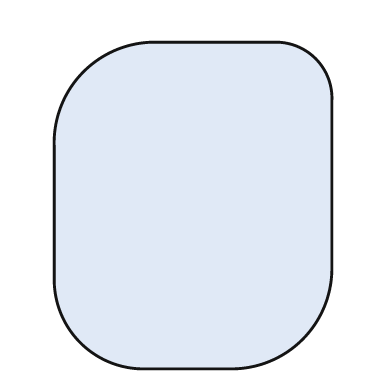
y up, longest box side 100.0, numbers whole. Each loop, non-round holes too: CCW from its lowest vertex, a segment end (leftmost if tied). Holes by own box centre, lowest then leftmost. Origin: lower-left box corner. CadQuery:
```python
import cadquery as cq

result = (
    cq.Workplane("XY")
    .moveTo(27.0, 0.0)
    .lineTo(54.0, 0.0)
    .threePointArc((76.0, 9.0), (85.0, 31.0))
    .lineTo(85.0, 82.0)
    .threePointArc((80.0, 95.0), (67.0, 100.0))
    .lineTo(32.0, 100.0)
    .threePointArc((9.0, 91.0), (0.0, 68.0))
    .lineTo(0.0, 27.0)
    .threePointArc((8.0, 8.0), (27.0, 0.0))
    .close()
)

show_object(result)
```